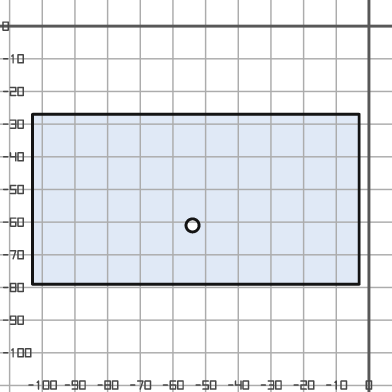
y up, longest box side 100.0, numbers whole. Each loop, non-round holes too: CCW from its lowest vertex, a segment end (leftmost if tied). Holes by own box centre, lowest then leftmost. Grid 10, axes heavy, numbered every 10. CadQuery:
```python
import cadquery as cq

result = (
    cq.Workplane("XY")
    .moveTo(-103.0, -79.0)
    .lineTo(-3.0, -79.0)
    .lineTo(-3.0, -27.0)
    .lineTo(-103.0, -27.0)
    .close()
    .moveTo(-54.0, -61.0)
    .circle(2.0)
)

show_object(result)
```